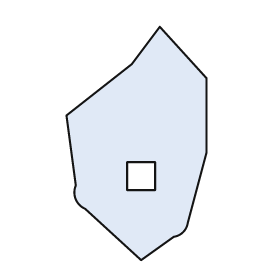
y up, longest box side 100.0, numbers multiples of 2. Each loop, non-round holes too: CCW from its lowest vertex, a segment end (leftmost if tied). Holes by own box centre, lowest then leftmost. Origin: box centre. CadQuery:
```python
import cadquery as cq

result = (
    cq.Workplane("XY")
    .moveTo(2.0, -50.0)
    .lineTo(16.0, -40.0)
    .threePointArc((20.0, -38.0), (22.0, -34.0))
    .lineTo(30.0, -4.0)
    .lineTo(30.0, 28.0)
    .lineTo(10.0, 50.0)
    .lineTo(-2.0, 34.0)
    .lineTo(-30.0, 12.0)
    .lineTo(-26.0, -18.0)
    .threePointArc((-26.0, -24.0), (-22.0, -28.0))
    .close()
    .moveTo(-4.0, -20.0)
    .lineTo(8.0, -20.0)
    .lineTo(8.0, -8.0)
    .lineTo(-4.0, -8.0)
    .close()
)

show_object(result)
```